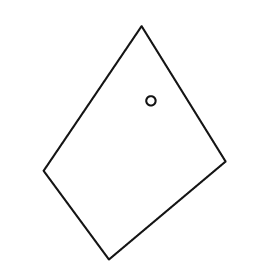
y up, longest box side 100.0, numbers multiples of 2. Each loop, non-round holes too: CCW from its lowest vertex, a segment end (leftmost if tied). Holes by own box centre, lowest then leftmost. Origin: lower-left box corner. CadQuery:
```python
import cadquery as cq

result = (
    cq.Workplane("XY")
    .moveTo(28.0, 0.0)
    .lineTo(78.0, 42.0)
    .lineTo(42.0, 100.0)
    .lineTo(0.0, 38.0)
    .close()
    .moveTo(46.0, 68.0)
    .circle(2.0)
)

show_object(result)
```